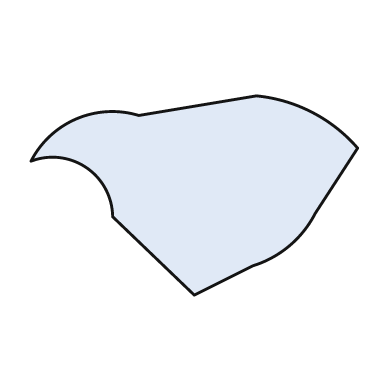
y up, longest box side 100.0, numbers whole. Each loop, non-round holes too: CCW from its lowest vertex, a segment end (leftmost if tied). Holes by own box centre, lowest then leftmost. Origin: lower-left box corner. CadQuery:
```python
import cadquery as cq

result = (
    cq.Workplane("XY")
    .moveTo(50.0, 0.0)
    .lineTo(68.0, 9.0)
    .threePointArc((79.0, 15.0), (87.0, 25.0))
    .lineTo(100.0, 45.0)
    .threePointArc((86.0, 56.0), (69.0, 61.0))
    .lineTo(33.0, 55.0)
    .threePointArc((14.0, 54.0), (0.0, 41.0))
    .threePointArc((17.0, 39.0), (25.0, 24.0))
    .close()
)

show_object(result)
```